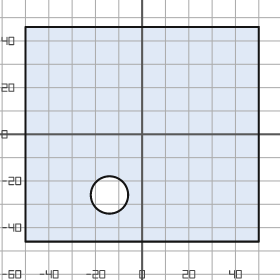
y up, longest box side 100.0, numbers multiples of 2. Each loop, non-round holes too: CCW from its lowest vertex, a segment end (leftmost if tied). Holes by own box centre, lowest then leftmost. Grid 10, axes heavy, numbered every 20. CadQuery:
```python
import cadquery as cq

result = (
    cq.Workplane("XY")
    .moveTo(-50.0, -46.0)
    .lineTo(50.0, -46.0)
    .lineTo(50.0, 46.0)
    .lineTo(-50.0, 46.0)
    .close()
    .moveTo(-14.0, -26.0)
    .circle(8.0)
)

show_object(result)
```